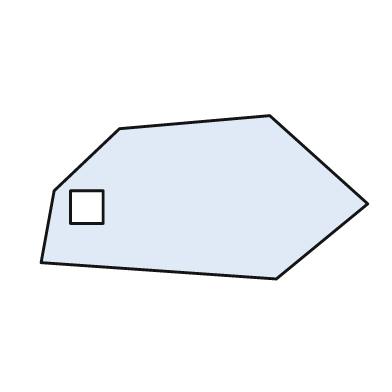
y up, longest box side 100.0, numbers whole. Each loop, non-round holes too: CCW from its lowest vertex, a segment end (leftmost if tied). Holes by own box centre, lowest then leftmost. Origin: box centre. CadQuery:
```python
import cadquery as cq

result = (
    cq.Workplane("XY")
    .moveTo(22.0, -25.0)
    .lineTo(50.0, -2.0)
    .lineTo(20.0, 25.0)
    .lineTo(-26.0, 21.0)
    .lineTo(-46.0, 2.0)
    .lineTo(-50.0, -20.0)
    .close()
    .moveTo(-41.0, -8.0)
    .lineTo(-31.0, -8.0)
    .lineTo(-31.0, 2.0)
    .lineTo(-41.0, 2.0)
    .close()
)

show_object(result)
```